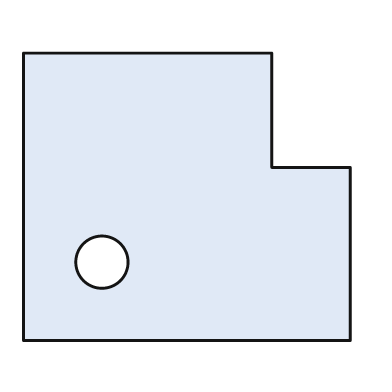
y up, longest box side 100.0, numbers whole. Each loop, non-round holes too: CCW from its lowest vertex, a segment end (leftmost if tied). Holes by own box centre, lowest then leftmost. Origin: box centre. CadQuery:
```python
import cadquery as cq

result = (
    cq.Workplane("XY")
    .moveTo(-50.0, -44.0)
    .lineTo(50.0, -44.0)
    .lineTo(50.0, 9.0)
    .lineTo(26.0, 9.0)
    .lineTo(26.0, 44.0)
    .lineTo(-50.0, 44.0)
    .close()
    .moveTo(-26.0, -20.0)
    .circle(8.0)
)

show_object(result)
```